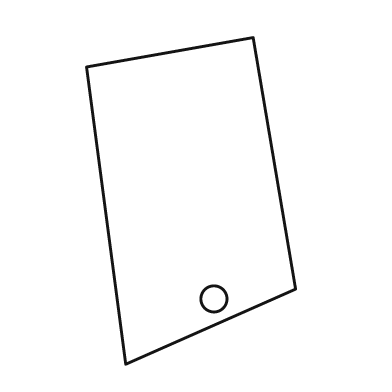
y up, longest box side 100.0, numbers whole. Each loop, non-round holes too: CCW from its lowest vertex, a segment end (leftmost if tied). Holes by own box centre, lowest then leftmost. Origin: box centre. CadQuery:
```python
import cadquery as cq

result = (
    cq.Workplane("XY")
    .moveTo(-20.0, -50.0)
    .lineTo(32.0, -27.0)
    .lineTo(19.0, 50.0)
    .lineTo(-32.0, 41.0)
    .close()
    .moveTo(7.0, -30.0)
    .circle(4.0)
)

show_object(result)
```